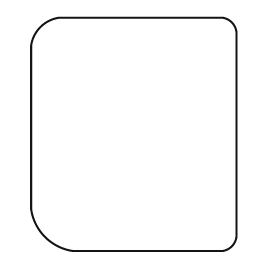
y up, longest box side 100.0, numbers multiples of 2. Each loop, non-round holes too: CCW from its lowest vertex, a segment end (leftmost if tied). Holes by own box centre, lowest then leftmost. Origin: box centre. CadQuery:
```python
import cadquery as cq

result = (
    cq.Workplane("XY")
    .moveTo(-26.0, -50.0)
    .lineTo(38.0, -50.0)
    .threePointArc((42.0, -48.0), (44.0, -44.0))
    .lineTo(44.0, 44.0)
    .threePointArc((42.0, 48.0), (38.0, 50.0))
    .lineTo(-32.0, 50.0)
    .threePointArc((-40.0, 46.0), (-44.0, 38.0))
    .lineTo(-44.0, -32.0)
    .threePointArc((-38.0, -44.0), (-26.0, -50.0))
    .close()
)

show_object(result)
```